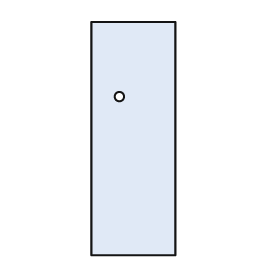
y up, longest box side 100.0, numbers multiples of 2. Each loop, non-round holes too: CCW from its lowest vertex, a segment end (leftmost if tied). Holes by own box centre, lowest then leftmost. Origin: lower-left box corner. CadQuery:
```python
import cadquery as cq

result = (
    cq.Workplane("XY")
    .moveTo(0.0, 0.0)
    .lineTo(36.0, 0.0)
    .lineTo(36.0, 100.0)
    .lineTo(0.0, 100.0)
    .close()
    .moveTo(12.0, 68.0)
    .circle(2.0)
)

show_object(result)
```